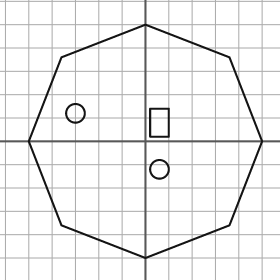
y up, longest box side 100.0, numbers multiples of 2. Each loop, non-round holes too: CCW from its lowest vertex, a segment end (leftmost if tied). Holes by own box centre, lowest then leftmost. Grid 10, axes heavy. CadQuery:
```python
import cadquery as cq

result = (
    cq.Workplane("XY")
    .moveTo(0.0, -50.0)
    .lineTo(36.0, -36.0)
    .lineTo(50.0, 0.0)
    .lineTo(36.0, 36.0)
    .lineTo(0.0, 50.0)
    .lineTo(-36.0, 36.0)
    .lineTo(-50.0, 0.0)
    .lineTo(-36.0, -36.0)
    .close()
    .moveTo(6.0, -12.0)
    .circle(4.0)
    .moveTo(2.0, 2.0)
    .lineTo(10.0, 2.0)
    .lineTo(10.0, 14.0)
    .lineTo(2.0, 14.0)
    .close()
    .moveTo(-30.0, 12.0)
    .circle(4.0)
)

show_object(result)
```